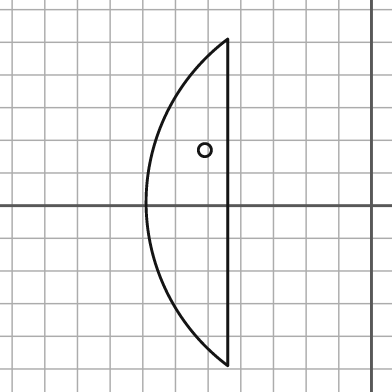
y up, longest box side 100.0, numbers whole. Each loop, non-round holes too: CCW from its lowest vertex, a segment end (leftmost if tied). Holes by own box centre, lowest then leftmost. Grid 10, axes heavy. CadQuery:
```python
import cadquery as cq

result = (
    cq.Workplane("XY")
    .moveTo(-44.0, -49.0)
    .lineTo(-44.0, 51.0)
    .threePointArc((-69.0, 1.0), (-44.0, -49.0))
    .close()
    .moveTo(-51.0, 17.0)
    .circle(2.0)
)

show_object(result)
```